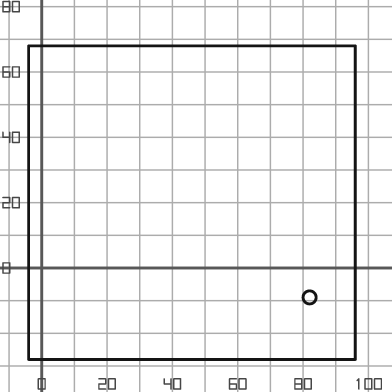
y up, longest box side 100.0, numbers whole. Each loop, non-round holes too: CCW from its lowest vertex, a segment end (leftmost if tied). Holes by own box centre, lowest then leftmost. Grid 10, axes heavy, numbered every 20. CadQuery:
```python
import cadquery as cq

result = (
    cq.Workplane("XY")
    .moveTo(-4.0, -28.0)
    .lineTo(96.0, -28.0)
    .lineTo(96.0, 68.0)
    .lineTo(-4.0, 68.0)
    .close()
    .moveTo(82.0, -9.0)
    .circle(2.0)
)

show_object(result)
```